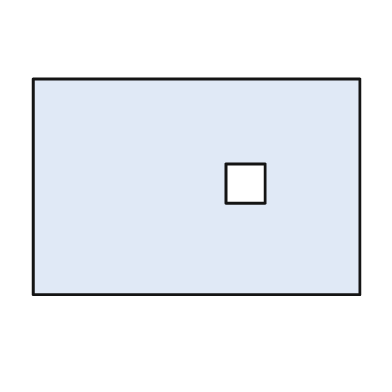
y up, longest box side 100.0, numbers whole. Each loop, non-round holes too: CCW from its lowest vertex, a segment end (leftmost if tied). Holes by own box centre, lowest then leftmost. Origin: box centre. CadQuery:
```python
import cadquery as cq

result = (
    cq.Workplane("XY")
    .moveTo(-50.0, -33.0)
    .lineTo(50.0, -33.0)
    .lineTo(50.0, 33.0)
    .lineTo(-50.0, 33.0)
    .close()
    .moveTo(9.0, -5.0)
    .lineTo(21.0, -5.0)
    .lineTo(21.0, 7.0)
    .lineTo(9.0, 7.0)
    .close()
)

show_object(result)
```